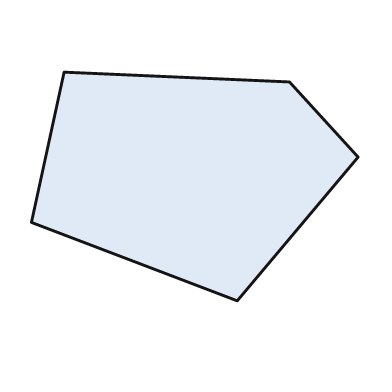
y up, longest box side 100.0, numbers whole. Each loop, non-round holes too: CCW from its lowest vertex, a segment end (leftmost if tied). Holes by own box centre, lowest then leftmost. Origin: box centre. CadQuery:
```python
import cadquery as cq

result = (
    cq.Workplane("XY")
    .moveTo(13.0, -35.0)
    .lineTo(50.0, 9.0)
    .lineTo(29.0, 32.0)
    .lineTo(-40.0, 35.0)
    .lineTo(-50.0, -11.0)
    .close()
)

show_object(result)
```